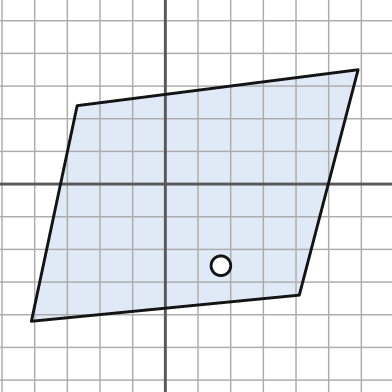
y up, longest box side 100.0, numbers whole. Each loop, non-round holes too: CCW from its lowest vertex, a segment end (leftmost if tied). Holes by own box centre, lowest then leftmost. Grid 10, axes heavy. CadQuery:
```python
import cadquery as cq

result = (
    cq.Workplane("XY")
    .moveTo(-41.0, -42.0)
    .lineTo(41.0, -34.0)
    .lineTo(59.0, 35.0)
    .lineTo(-27.0, 24.0)
    .close()
    .moveTo(17.0, -25.0)
    .circle(3.0)
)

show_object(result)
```